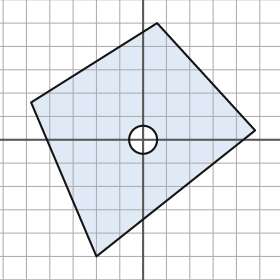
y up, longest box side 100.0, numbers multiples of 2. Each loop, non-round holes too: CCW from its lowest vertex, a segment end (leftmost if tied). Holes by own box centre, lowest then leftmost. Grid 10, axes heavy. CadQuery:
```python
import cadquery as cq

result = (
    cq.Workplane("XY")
    .moveTo(-20.0, -50.0)
    .lineTo(48.0, 4.0)
    .lineTo(6.0, 50.0)
    .lineTo(-48.0, 16.0)
    .close()
    .moveTo(0.0, 0.0)
    .circle(6.0)
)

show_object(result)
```